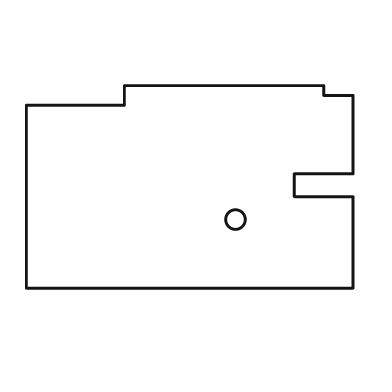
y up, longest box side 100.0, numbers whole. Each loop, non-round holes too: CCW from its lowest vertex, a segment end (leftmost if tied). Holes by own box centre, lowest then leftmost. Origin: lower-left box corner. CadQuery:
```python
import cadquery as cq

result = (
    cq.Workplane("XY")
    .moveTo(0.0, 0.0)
    .lineTo(100.0, 0.0)
    .lineTo(100.0, 28.0)
    .lineTo(82.0, 28.0)
    .lineTo(82.0, 35.0)
    .lineTo(100.0, 35.0)
    .lineTo(100.0, 59.0)
    .lineTo(91.0, 59.0)
    .lineTo(91.0, 62.0)
    .lineTo(30.0, 62.0)
    .lineTo(30.0, 56.0)
    .lineTo(0.0, 56.0)
    .close()
    .moveTo(64.0, 21.0)
    .circle(3.0)
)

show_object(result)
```